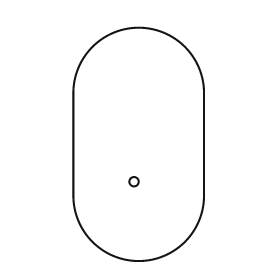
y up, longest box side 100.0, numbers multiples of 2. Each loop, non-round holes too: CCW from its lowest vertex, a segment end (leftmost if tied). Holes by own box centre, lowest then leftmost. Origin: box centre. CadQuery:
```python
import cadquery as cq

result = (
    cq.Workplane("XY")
    .moveTo(-28.0, -22.0)
    .threePointArc((0.0, -50.0), (28.0, -22.0))
    .lineTo(28.0, 22.0)
    .threePointArc((0.0, 50.0), (-28.0, 22.0))
    .close()
    .moveTo(-2.0, -16.0)
    .circle(2.0)
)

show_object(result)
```